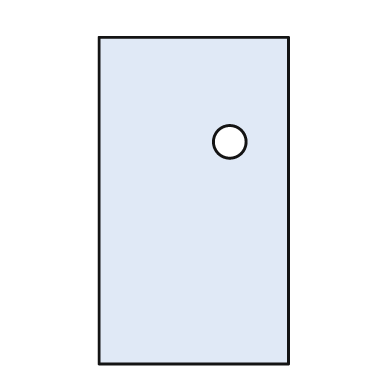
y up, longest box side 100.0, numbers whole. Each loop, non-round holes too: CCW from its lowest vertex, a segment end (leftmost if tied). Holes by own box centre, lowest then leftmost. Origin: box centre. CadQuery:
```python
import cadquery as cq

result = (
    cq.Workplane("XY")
    .moveTo(-29.0, -50.0)
    .lineTo(29.0, -50.0)
    .lineTo(29.0, 50.0)
    .lineTo(-29.0, 50.0)
    .close()
    .moveTo(11.0, 18.0)
    .circle(5.0)
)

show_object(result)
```